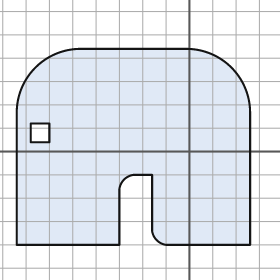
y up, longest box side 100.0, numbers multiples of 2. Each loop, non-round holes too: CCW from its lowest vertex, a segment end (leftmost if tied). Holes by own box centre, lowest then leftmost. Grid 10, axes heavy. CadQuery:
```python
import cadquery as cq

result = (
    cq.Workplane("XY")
    .moveTo(-74.0, -40.0)
    .lineTo(-30.0, -40.0)
    .lineTo(-30.0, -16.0)
    .threePointArc((-28.0, -12.0), (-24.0, -10.0))
    .lineTo(-16.0, -10.0)
    .lineTo(-16.0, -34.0)
    .threePointArc((-14.0, -38.0), (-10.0, -40.0))
    .lineTo(26.0, -40.0)
    .lineTo(26.0, 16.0)
    .threePointArc((18.0, 36.0), (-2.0, 44.0))
    .lineTo(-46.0, 44.0)
    .threePointArc((-66.0, 36.0), (-74.0, 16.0))
    .close()
    .moveTo(-68.0, 4.0)
    .lineTo(-60.0, 4.0)
    .lineTo(-60.0, 12.0)
    .lineTo(-68.0, 12.0)
    .close()
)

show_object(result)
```